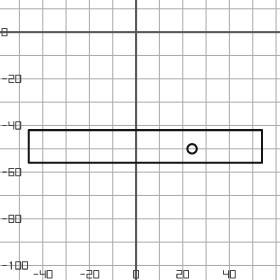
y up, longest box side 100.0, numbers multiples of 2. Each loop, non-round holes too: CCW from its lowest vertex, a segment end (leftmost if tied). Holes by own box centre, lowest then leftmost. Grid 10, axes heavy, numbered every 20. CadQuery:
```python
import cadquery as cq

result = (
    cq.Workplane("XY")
    .moveTo(-46.0, -56.0)
    .lineTo(54.0, -56.0)
    .lineTo(54.0, -42.0)
    .lineTo(-46.0, -42.0)
    .close()
    .moveTo(24.0, -50.0)
    .circle(2.0)
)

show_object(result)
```